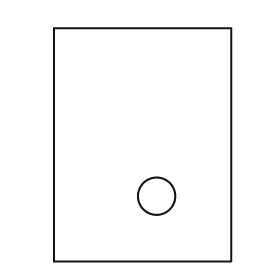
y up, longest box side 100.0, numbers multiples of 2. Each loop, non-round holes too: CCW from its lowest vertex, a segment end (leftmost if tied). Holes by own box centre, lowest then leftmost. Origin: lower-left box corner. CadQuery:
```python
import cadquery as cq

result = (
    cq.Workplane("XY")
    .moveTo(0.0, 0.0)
    .lineTo(76.0, 0.0)
    .lineTo(76.0, 100.0)
    .lineTo(0.0, 100.0)
    .close()
    .moveTo(44.0, 28.0)
    .circle(8.0)
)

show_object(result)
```